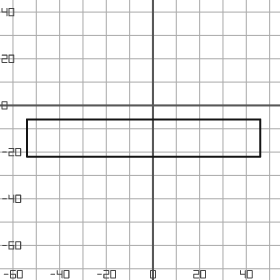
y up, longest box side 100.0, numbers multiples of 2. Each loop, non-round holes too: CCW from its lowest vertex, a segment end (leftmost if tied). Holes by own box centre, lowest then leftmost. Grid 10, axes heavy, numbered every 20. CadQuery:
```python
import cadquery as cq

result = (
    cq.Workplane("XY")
    .moveTo(-54.0, -22.0)
    .lineTo(46.0, -22.0)
    .lineTo(46.0, -6.0)
    .lineTo(-54.0, -6.0)
    .close()
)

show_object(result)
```